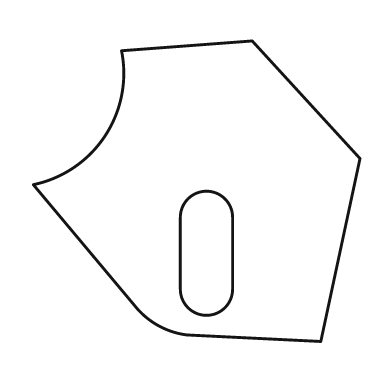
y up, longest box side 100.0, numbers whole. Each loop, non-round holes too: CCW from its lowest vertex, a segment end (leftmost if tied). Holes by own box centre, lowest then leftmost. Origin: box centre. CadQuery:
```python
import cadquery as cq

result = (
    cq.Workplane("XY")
    .moveTo(38.0, -46.0)
    .lineTo(50.0, 10.0)
    .lineTo(17.0, 46.0)
    .lineTo(-23.0, 43.0)
    .threePointArc((-28.0, 17.0), (-50.0, 2.0))
    .lineTo(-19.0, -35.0)
    .threePointArc((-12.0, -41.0), (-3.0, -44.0))
    .close()
    .moveTo(-5.0, -30.0)
    .threePointArc((3.0, -38.0), (11.0, -30.0))
    .lineTo(11.0, -8.0)
    .threePointArc((3.0, 0.0), (-5.0, -8.0))
    .close()
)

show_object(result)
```